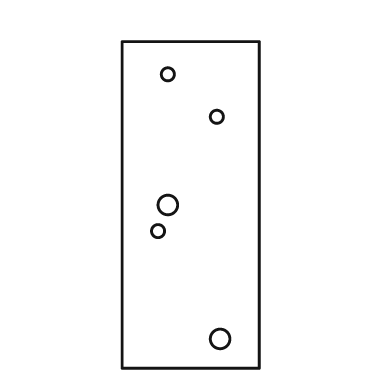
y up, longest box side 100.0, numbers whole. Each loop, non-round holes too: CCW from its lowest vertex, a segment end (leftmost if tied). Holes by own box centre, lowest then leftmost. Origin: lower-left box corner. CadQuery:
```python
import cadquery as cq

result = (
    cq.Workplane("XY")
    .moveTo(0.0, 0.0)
    .lineTo(42.0, 0.0)
    .lineTo(42.0, 100.0)
    .lineTo(0.0, 100.0)
    .close()
    .moveTo(30.0, 9.0)
    .circle(3.0)
    .moveTo(11.0, 42.0)
    .circle(2.0)
    .moveTo(14.0, 50.0)
    .circle(3.0)
    .moveTo(29.0, 77.0)
    .circle(2.0)
    .moveTo(14.0, 90.0)
    .circle(2.0)
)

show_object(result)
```